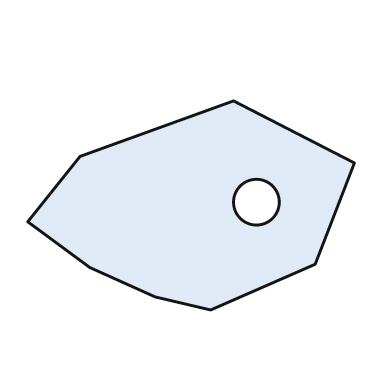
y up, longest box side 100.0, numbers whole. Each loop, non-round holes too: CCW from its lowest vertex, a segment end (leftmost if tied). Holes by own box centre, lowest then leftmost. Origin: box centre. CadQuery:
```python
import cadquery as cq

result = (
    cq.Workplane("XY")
    .moveTo(6.0, -32.0)
    .lineTo(38.0, -18.0)
    .lineTo(50.0, 13.0)
    .lineTo(13.0, 32.0)
    .lineTo(-34.0, 15.0)
    .lineTo(-50.0, -5.0)
    .lineTo(-31.0, -19.0)
    .lineTo(-11.0, -28.0)
    .close()
    .moveTo(20.0, 1.0)
    .circle(7.0)
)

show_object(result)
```